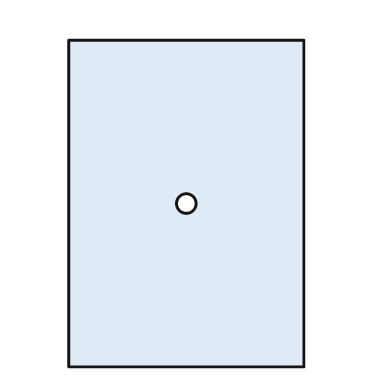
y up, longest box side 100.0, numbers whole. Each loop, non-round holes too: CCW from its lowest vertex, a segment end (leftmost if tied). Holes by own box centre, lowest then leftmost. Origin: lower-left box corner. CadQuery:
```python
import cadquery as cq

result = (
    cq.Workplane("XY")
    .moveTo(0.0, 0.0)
    .lineTo(72.0, 0.0)
    .lineTo(72.0, 100.0)
    .lineTo(0.0, 100.0)
    .close()
    .moveTo(36.0, 50.0)
    .circle(3.0)
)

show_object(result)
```